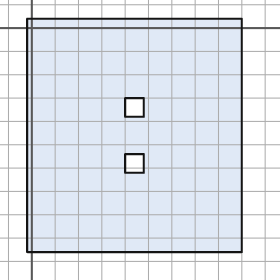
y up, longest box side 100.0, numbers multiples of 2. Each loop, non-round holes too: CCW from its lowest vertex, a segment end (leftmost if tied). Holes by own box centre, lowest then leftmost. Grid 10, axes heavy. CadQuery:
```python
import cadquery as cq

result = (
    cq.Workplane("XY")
    .moveTo(-2.0, -96.0)
    .lineTo(90.0, -96.0)
    .lineTo(90.0, 4.0)
    .lineTo(-2.0, 4.0)
    .close()
    .moveTo(40.0, -62.0)
    .lineTo(48.0, -62.0)
    .lineTo(48.0, -54.0)
    .lineTo(40.0, -54.0)
    .close()
    .moveTo(40.0, -38.0)
    .lineTo(48.0, -38.0)
    .lineTo(48.0, -30.0)
    .lineTo(40.0, -30.0)
    .close()
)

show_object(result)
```